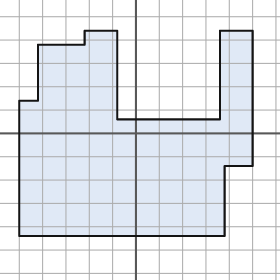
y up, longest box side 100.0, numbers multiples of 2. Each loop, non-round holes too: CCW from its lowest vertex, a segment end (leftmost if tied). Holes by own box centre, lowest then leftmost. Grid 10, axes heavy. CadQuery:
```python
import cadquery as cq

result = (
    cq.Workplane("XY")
    .moveTo(-50.0, -44.0)
    .lineTo(38.0, -44.0)
    .lineTo(38.0, -14.0)
    .lineTo(50.0, -14.0)
    .lineTo(50.0, 44.0)
    .lineTo(36.0, 44.0)
    .lineTo(36.0, 6.0)
    .lineTo(-8.0, 6.0)
    .lineTo(-8.0, 44.0)
    .lineTo(-22.0, 44.0)
    .lineTo(-22.0, 38.0)
    .lineTo(-42.0, 38.0)
    .lineTo(-42.0, 14.0)
    .lineTo(-50.0, 14.0)
    .close()
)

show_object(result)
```